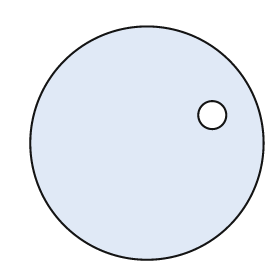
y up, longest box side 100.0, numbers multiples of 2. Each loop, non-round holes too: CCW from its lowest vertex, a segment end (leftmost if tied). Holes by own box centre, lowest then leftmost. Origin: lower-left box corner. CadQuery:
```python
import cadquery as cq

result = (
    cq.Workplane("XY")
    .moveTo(50.0, 50.0)
    .circle(50.0)
    .moveTo(78.0, 62.0)
    .circle(6.0)
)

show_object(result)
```